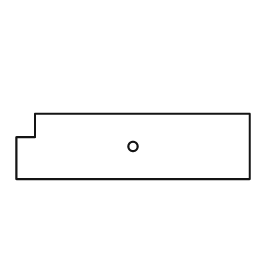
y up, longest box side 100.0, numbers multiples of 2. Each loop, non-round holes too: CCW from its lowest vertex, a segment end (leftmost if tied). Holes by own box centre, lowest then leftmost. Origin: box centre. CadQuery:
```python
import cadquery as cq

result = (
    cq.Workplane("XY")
    .moveTo(-50.0, -14.0)
    .lineTo(50.0, -14.0)
    .lineTo(50.0, 14.0)
    .lineTo(-42.0, 14.0)
    .lineTo(-42.0, 4.0)
    .lineTo(-50.0, 4.0)
    .close()
    .moveTo(0.0, 0.0)
    .circle(2.0)
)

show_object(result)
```